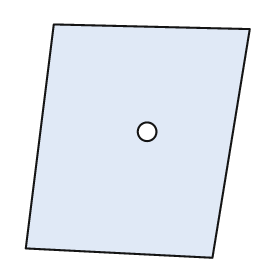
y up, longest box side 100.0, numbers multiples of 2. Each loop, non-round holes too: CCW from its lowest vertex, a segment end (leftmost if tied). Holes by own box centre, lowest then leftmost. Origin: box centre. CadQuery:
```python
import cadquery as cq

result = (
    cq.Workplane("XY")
    .moveTo(32.0, -50.0)
    .lineTo(48.0, 48.0)
    .lineTo(-36.0, 50.0)
    .lineTo(-48.0, -46.0)
    .close()
    .moveTo(4.0, 4.0)
    .circle(4.0)
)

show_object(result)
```